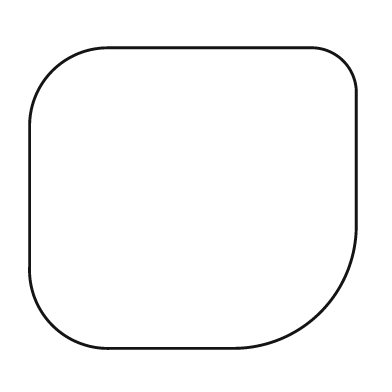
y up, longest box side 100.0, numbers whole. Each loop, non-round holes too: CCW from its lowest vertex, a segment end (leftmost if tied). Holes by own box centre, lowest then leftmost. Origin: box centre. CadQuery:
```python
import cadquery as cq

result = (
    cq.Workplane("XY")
    .moveTo(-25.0, -46.0)
    .lineTo(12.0, -46.0)
    .threePointArc((39.0, -35.0), (50.0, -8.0))
    .lineTo(50.0, 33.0)
    .threePointArc((46.0, 42.0), (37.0, 46.0))
    .lineTo(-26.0, 46.0)
    .threePointArc((-43.0, 39.0), (-50.0, 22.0))
    .lineTo(-50.0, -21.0)
    .threePointArc((-43.0, -39.0), (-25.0, -46.0))
    .close()
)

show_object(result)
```